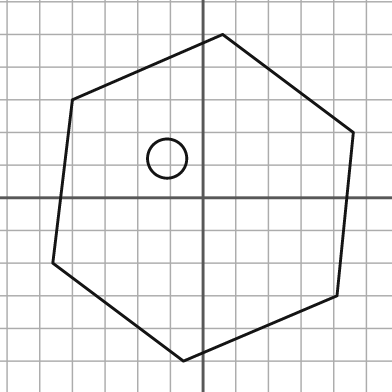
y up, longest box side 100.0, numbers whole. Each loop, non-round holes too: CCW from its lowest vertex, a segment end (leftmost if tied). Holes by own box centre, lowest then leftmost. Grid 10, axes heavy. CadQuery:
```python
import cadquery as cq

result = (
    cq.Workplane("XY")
    .moveTo(-6.0, -50.0)
    .lineTo(41.0, -30.0)
    .lineTo(46.0, 20.0)
    .lineTo(6.0, 50.0)
    .lineTo(-40.0, 30.0)
    .lineTo(-46.0, -20.0)
    .close()
    .moveTo(-11.0, 12.0)
    .circle(6.0)
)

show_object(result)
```